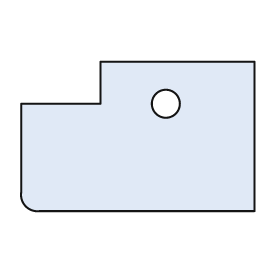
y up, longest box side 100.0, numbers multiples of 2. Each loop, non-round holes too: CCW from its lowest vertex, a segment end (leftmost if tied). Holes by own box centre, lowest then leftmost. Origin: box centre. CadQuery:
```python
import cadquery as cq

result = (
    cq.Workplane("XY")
    .moveTo(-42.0, -32.0)
    .lineTo(50.0, -32.0)
    .lineTo(50.0, 32.0)
    .lineTo(-16.0, 32.0)
    .lineTo(-16.0, 14.0)
    .lineTo(-50.0, 14.0)
    .lineTo(-50.0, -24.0)
    .threePointArc((-48.0, -30.0), (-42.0, -32.0))
    .close()
    .moveTo(12.0, 14.0)
    .circle(6.0)
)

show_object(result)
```